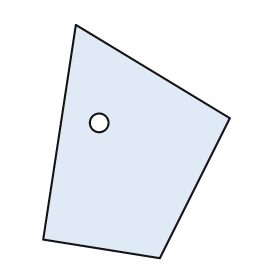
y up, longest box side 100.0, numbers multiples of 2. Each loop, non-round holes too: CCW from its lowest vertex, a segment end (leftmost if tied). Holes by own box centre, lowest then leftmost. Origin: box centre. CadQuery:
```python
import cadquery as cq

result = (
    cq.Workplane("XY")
    .moveTo(10.0, -50.0)
    .lineTo(40.0, 10.0)
    .lineTo(-26.0, 50.0)
    .lineTo(-40.0, -42.0)
    .close()
    .moveTo(-16.0, 8.0)
    .circle(4.0)
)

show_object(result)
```